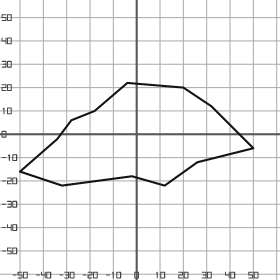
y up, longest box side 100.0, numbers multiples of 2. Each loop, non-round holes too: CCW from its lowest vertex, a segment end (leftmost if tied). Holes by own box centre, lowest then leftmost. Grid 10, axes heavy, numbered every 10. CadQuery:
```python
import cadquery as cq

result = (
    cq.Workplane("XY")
    .moveTo(-32.0, -22.0)
    .lineTo(-2.0, -18.0)
    .lineTo(12.0, -22.0)
    .lineTo(26.0, -12.0)
    .lineTo(50.0, -6.0)
    .lineTo(32.0, 12.0)
    .lineTo(20.0, 20.0)
    .lineTo(-4.0, 22.0)
    .lineTo(-18.0, 10.0)
    .lineTo(-28.0, 6.0)
    .lineTo(-34.0, -2.0)
    .lineTo(-50.0, -16.0)
    .close()
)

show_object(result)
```